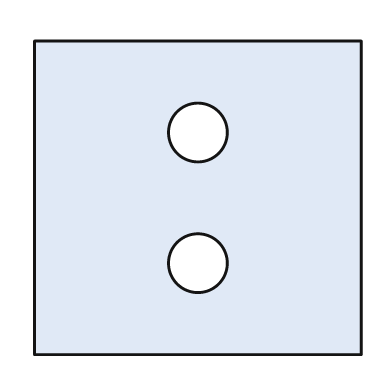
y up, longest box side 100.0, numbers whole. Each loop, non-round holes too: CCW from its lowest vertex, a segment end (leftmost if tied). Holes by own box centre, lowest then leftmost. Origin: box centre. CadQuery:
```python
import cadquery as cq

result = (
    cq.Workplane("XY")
    .moveTo(-50.0, -48.0)
    .lineTo(50.0, -48.0)
    .lineTo(50.0, 48.0)
    .lineTo(-50.0, 48.0)
    .close()
    .moveTo(0.0, -20.0)
    .circle(9.0)
    .moveTo(0.0, 20.0)
    .circle(9.0)
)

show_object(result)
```